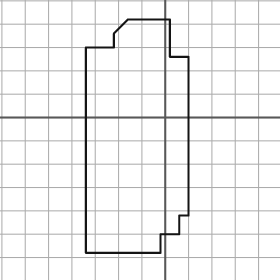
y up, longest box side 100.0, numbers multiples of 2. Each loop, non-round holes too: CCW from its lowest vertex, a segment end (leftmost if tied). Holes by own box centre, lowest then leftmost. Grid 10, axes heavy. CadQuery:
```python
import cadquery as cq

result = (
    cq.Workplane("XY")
    .moveTo(-34.0, -58.0)
    .lineTo(-2.0, -58.0)
    .lineTo(-2.0, -50.0)
    .lineTo(6.0, -50.0)
    .lineTo(6.0, -42.0)
    .lineTo(10.0, -42.0)
    .lineTo(10.0, 26.0)
    .lineTo(2.0, 26.0)
    .lineTo(2.0, 42.0)
    .lineTo(-16.0, 42.0)
    .lineTo(-22.0, 36.0)
    .lineTo(-22.0, 30.0)
    .lineTo(-34.0, 30.0)
    .close()
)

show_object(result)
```